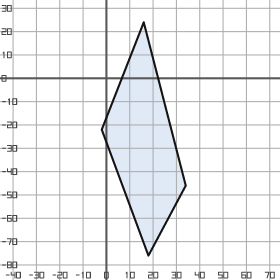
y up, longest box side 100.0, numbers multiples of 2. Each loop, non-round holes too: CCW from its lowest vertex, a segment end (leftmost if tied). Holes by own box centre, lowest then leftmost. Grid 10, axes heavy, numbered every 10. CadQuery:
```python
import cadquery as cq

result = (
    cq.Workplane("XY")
    .moveTo(18.0, -76.0)
    .lineTo(34.0, -46.0)
    .lineTo(16.0, 24.0)
    .lineTo(-2.0, -22.0)
    .close()
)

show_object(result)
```